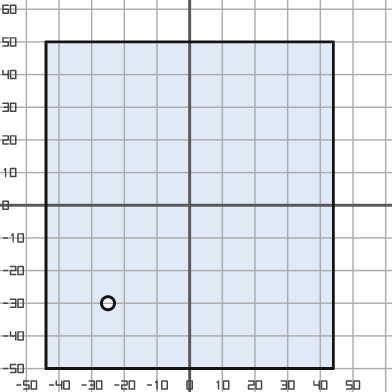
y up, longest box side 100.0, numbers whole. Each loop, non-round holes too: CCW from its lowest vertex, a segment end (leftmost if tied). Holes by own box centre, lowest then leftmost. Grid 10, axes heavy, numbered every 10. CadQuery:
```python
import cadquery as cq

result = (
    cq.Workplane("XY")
    .moveTo(-44.0, -50.0)
    .lineTo(44.0, -50.0)
    .lineTo(44.0, 50.0)
    .lineTo(-44.0, 50.0)
    .close()
    .moveTo(-25.0, -30.0)
    .circle(2.0)
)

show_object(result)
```